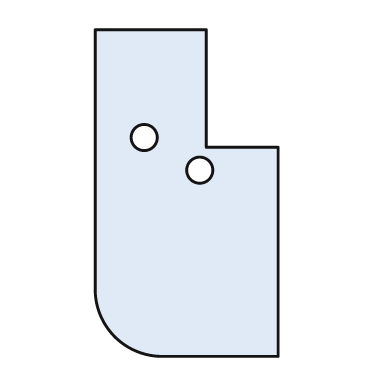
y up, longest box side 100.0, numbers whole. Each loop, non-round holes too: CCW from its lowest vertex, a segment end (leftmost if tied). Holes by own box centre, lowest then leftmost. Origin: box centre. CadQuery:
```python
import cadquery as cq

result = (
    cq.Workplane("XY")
    .moveTo(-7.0, -50.0)
    .lineTo(28.0, -50.0)
    .lineTo(28.0, 14.0)
    .lineTo(6.0, 14.0)
    .lineTo(6.0, 50.0)
    .lineTo(-28.0, 50.0)
    .lineTo(-28.0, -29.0)
    .threePointArc((-22.0, -44.0), (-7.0, -50.0))
    .close()
    .moveTo(4.0, 7.0)
    .circle(4.0)
    .moveTo(-13.0, 17.0)
    .circle(4.0)
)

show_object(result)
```